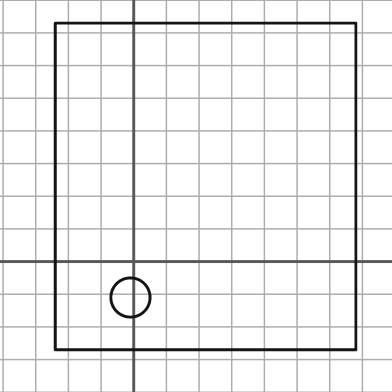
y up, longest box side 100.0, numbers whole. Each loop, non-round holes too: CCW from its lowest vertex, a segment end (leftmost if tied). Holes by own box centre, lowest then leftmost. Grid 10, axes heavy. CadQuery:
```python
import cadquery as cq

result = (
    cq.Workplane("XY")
    .moveTo(-24.0, -27.0)
    .lineTo(68.0, -27.0)
    .lineTo(68.0, 73.0)
    .lineTo(-24.0, 73.0)
    .close()
    .moveTo(-1.0, -11.0)
    .circle(6.0)
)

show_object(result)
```